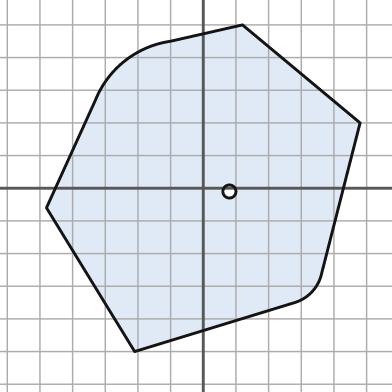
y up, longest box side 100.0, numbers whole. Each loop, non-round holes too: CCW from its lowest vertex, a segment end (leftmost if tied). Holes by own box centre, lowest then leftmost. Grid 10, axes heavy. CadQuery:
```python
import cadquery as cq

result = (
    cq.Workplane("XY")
    .moveTo(-21.0, -50.0)
    .lineTo(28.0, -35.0)
    .threePointArc((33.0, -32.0), (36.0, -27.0))
    .lineTo(48.0, 20.0)
    .lineTo(12.0, 50.0)
    .lineTo(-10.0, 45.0)
    .threePointArc((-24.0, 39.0), (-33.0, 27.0))
    .lineTo(-48.0, -6.0)
    .close()
    .moveTo(8.0, -1.0)
    .circle(2.0)
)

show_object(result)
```